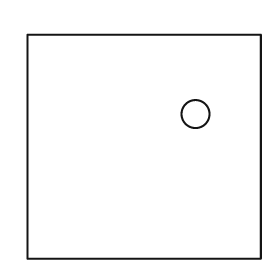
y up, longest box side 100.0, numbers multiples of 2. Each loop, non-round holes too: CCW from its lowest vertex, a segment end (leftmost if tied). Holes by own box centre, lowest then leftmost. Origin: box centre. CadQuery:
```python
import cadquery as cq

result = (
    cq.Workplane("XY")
    .moveTo(-50.0, -48.0)
    .lineTo(50.0, -48.0)
    .lineTo(50.0, 48.0)
    .lineTo(-50.0, 48.0)
    .close()
    .moveTo(22.0, 14.0)
    .circle(6.0)
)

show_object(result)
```